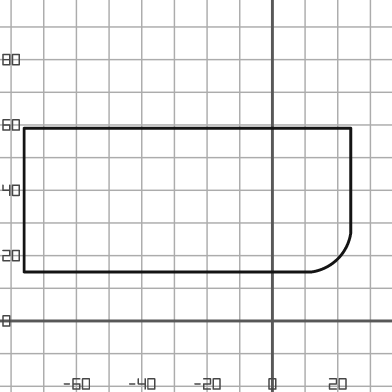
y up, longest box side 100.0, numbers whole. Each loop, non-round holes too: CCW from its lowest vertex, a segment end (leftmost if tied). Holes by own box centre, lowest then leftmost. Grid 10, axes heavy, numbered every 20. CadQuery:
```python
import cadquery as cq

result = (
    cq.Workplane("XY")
    .moveTo(-76.0, 15.0)
    .lineTo(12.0, 15.0)
    .threePointArc((20.0, 19.0), (24.0, 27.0))
    .lineTo(24.0, 59.0)
    .lineTo(-76.0, 59.0)
    .close()
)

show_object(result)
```